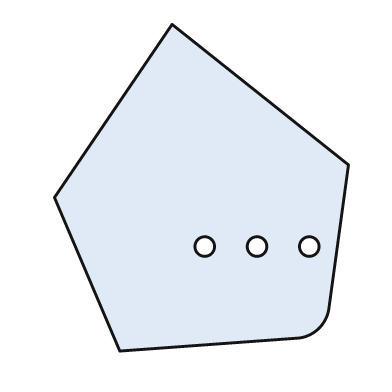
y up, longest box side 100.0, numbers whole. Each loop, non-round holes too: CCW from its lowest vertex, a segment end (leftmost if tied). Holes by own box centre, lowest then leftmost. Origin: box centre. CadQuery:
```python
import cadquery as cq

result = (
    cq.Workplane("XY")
    .moveTo(-25.0, -50.0)
    .lineTo(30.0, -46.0)
    .threePointArc((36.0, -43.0), (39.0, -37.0))
    .lineTo(45.0, 7.0)
    .lineTo(-9.0, 50.0)
    .lineTo(-45.0, -3.0)
    .close()
    .moveTo(1.0, -18.0)
    .circle(3.0)
    .moveTo(17.0, -18.0)
    .circle(3.0)
    .moveTo(33.0, -18.0)
    .circle(3.0)
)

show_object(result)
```